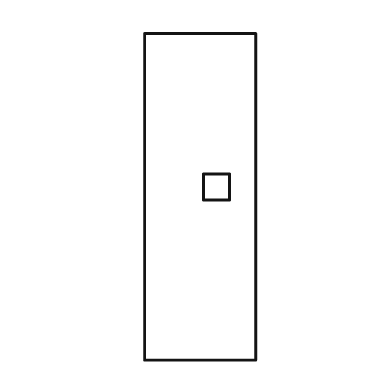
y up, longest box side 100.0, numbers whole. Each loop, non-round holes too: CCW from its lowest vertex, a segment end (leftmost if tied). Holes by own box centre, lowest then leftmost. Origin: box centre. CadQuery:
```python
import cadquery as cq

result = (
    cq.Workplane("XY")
    .moveTo(-17.0, -50.0)
    .lineTo(17.0, -50.0)
    .lineTo(17.0, 50.0)
    .lineTo(-17.0, 50.0)
    .close()
    .moveTo(1.0, -1.0)
    .lineTo(9.0, -1.0)
    .lineTo(9.0, 7.0)
    .lineTo(1.0, 7.0)
    .close()
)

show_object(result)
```